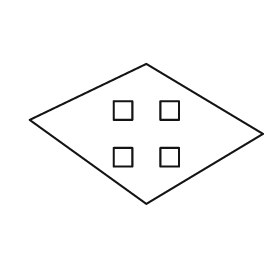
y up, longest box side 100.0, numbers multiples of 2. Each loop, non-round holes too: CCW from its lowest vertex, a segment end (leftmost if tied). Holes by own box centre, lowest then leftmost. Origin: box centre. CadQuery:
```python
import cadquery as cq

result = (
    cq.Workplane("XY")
    .moveTo(0.0, -30.0)
    .lineTo(50.0, 0.0)
    .lineTo(0.0, 30.0)
    .lineTo(-50.0, 6.0)
    .close()
    .moveTo(-14.0, -14.0)
    .lineTo(-6.0, -14.0)
    .lineTo(-6.0, -6.0)
    .lineTo(-14.0, -6.0)
    .close()
    .moveTo(6.0, -14.0)
    .lineTo(14.0, -14.0)
    .lineTo(14.0, -6.0)
    .lineTo(6.0, -6.0)
    .close()
    .moveTo(-14.0, 6.0)
    .lineTo(-6.0, 6.0)
    .lineTo(-6.0, 14.0)
    .lineTo(-14.0, 14.0)
    .close()
    .moveTo(6.0, 6.0)
    .lineTo(14.0, 6.0)
    .lineTo(14.0, 14.0)
    .lineTo(6.0, 14.0)
    .close()
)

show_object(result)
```